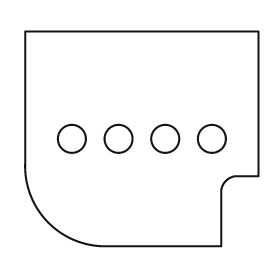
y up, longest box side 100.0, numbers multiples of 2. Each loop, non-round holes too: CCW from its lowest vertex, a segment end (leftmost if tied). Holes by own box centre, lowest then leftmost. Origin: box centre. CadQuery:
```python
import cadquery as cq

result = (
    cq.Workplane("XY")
    .moveTo(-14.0, -46.0)
    .lineTo(34.0, -46.0)
    .lineTo(34.0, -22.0)
    .threePointArc((36.0, -18.0), (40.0, -16.0))
    .lineTo(50.0, -16.0)
    .lineTo(50.0, 46.0)
    .lineTo(-50.0, 46.0)
    .lineTo(-50.0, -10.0)
    .threePointArc((-40.0, -36.0), (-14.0, -46.0))
    .close()
    .moveTo(-30.0, 0.0)
    .circle(6.0)
    .moveTo(-10.0, 0.0)
    .circle(6.0)
    .moveTo(10.0, 0.0)
    .circle(6.0)
    .moveTo(30.0, 0.0)
    .circle(6.0)
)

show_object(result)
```